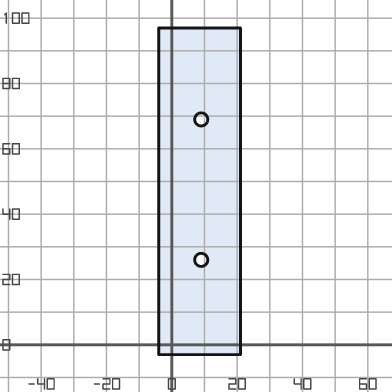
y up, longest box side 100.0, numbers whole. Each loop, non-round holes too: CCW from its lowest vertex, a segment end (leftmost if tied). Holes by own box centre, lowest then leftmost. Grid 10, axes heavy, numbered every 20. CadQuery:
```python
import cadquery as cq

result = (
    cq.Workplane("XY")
    .moveTo(-4.0, -3.0)
    .lineTo(21.0, -3.0)
    .lineTo(21.0, 97.0)
    .lineTo(-4.0, 97.0)
    .close()
    .moveTo(9.0, 26.0)
    .circle(2.0)
    .moveTo(9.0, 69.0)
    .circle(2.0)
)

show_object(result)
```